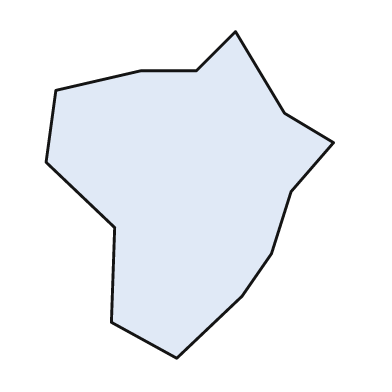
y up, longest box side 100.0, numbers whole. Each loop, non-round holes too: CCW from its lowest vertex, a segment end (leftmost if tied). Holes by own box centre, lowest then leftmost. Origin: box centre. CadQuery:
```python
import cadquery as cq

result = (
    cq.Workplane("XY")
    .moveTo(-4.0, -50.0)
    .lineTo(16.0, -31.0)
    .lineTo(25.0, -18.0)
    .lineTo(31.0, 1.0)
    .lineTo(44.0, 16.0)
    .lineTo(29.0, 25.0)
    .lineTo(14.0, 50.0)
    .lineTo(2.0, 38.0)
    .lineTo(-15.0, 38.0)
    .lineTo(-41.0, 32.0)
    .lineTo(-44.0, 10.0)
    .lineTo(-23.0, -10.0)
    .lineTo(-24.0, -39.0)
    .close()
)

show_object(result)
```